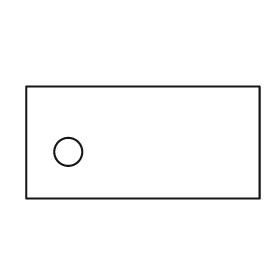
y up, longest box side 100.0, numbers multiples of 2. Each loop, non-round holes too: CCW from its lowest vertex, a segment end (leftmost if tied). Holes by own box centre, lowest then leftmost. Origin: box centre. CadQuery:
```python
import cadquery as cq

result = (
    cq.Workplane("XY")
    .moveTo(-50.0, -24.0)
    .lineTo(50.0, -24.0)
    .lineTo(50.0, 24.0)
    .lineTo(-50.0, 24.0)
    .close()
    .moveTo(-32.0, -4.0)
    .circle(6.0)
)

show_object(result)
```